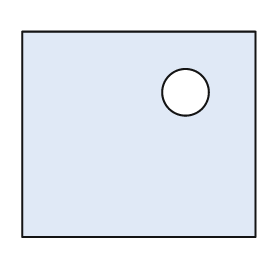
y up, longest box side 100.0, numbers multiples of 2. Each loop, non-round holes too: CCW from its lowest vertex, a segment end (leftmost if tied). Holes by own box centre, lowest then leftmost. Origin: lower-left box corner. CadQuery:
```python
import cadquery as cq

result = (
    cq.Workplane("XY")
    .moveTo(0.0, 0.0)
    .lineTo(100.0, 0.0)
    .lineTo(100.0, 88.0)
    .lineTo(0.0, 88.0)
    .close()
    .moveTo(70.0, 62.0)
    .circle(10.0)
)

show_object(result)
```